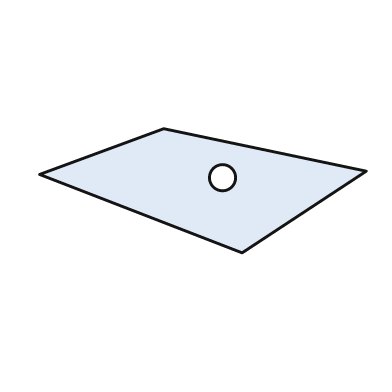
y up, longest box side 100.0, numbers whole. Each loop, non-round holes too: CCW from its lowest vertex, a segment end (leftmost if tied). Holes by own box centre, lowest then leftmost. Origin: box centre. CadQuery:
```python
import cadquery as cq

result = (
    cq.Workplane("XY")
    .moveTo(12.0, -19.0)
    .lineTo(50.0, 6.0)
    .lineTo(-12.0, 19.0)
    .lineTo(-50.0, 5.0)
    .close()
    .moveTo(6.0, 4.0)
    .circle(4.0)
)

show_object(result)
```